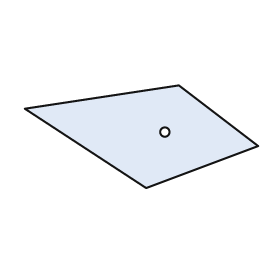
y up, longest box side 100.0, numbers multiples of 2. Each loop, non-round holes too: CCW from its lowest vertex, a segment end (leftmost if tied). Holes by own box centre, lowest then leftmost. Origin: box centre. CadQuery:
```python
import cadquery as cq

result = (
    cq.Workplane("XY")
    .moveTo(2.0, -22.0)
    .lineTo(50.0, -4.0)
    .lineTo(16.0, 22.0)
    .lineTo(-50.0, 12.0)
    .close()
    .moveTo(10.0, 2.0)
    .circle(2.0)
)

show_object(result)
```